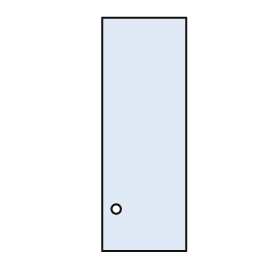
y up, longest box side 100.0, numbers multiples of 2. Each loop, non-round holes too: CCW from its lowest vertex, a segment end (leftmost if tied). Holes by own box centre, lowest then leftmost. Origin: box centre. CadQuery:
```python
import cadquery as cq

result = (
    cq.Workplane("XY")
    .moveTo(-18.0, -50.0)
    .lineTo(18.0, -50.0)
    .lineTo(18.0, 50.0)
    .lineTo(-18.0, 50.0)
    .close()
    .moveTo(-12.0, -32.0)
    .circle(2.0)
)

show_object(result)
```